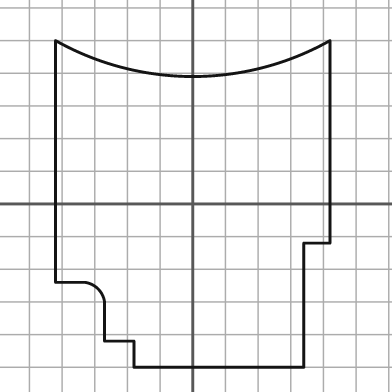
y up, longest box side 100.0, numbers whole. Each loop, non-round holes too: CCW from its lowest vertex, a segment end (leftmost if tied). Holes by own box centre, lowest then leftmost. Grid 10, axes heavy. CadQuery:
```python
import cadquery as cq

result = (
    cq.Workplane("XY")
    .moveTo(-18.0, -50.0)
    .lineTo(34.0, -50.0)
    .lineTo(34.0, -12.0)
    .lineTo(42.0, -12.0)
    .lineTo(42.0, 50.0)
    .threePointArc((0.0, 39.0), (-42.0, 50.0))
    .lineTo(-42.0, -24.0)
    .lineTo(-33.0, -24.0)
    .threePointArc((-29.0, -26.0), (-27.0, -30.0))
    .lineTo(-27.0, -42.0)
    .lineTo(-18.0, -42.0)
    .close()
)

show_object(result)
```